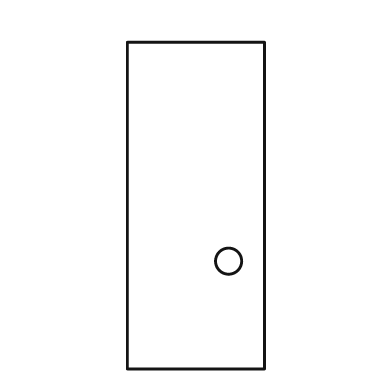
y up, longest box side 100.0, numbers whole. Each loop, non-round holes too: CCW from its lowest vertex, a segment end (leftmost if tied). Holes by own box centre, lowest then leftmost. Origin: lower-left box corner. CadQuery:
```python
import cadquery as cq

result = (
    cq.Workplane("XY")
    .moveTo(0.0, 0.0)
    .lineTo(42.0, 0.0)
    .lineTo(42.0, 100.0)
    .lineTo(0.0, 100.0)
    .close()
    .moveTo(31.0, 33.0)
    .circle(4.0)
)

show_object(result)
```